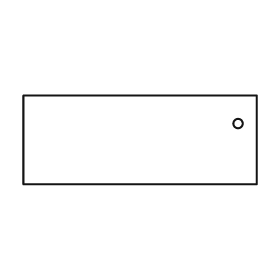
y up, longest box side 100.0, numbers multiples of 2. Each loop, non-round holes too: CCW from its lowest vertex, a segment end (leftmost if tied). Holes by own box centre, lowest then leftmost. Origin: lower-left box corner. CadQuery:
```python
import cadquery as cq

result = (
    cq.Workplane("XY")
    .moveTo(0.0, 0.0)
    .lineTo(100.0, 0.0)
    .lineTo(100.0, 38.0)
    .lineTo(0.0, 38.0)
    .close()
    .moveTo(92.0, 26.0)
    .circle(2.0)
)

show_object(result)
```